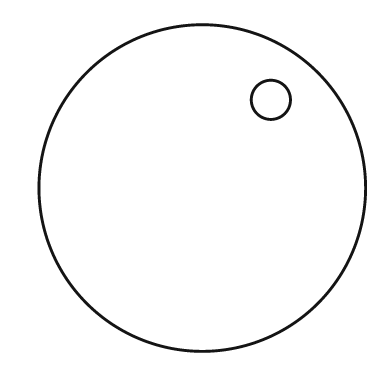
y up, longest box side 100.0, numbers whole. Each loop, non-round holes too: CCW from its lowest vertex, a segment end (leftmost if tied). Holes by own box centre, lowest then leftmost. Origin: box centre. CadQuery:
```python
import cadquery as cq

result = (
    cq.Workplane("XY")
    .moveTo(0.0, 0.0)
    .circle(50.0)
    .moveTo(21.0, 27.0)
    .circle(6.0)
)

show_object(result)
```